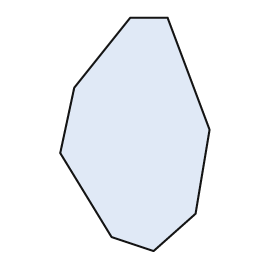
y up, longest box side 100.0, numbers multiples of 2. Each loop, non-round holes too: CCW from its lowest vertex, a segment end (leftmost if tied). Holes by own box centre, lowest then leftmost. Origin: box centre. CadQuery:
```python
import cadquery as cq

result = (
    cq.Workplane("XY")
    .moveTo(8.0, -50.0)
    .lineTo(26.0, -34.0)
    .lineTo(32.0, 2.0)
    .lineTo(14.0, 50.0)
    .lineTo(-2.0, 50.0)
    .lineTo(-26.0, 20.0)
    .lineTo(-32.0, -8.0)
    .lineTo(-10.0, -44.0)
    .close()
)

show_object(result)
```